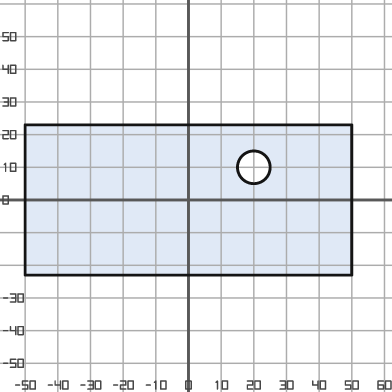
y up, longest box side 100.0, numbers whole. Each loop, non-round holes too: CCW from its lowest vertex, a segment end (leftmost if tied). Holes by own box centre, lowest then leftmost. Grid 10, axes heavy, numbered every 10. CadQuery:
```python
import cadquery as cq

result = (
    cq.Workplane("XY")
    .moveTo(-50.0, -23.0)
    .lineTo(50.0, -23.0)
    .lineTo(50.0, 23.0)
    .lineTo(-50.0, 23.0)
    .close()
    .moveTo(20.0, 10.0)
    .circle(5.0)
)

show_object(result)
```